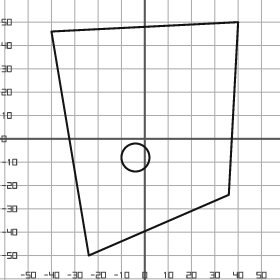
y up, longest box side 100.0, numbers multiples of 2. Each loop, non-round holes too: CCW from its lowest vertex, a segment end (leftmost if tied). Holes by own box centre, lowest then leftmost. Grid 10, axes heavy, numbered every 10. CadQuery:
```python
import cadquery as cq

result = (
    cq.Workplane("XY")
    .moveTo(-24.0, -50.0)
    .lineTo(36.0, -24.0)
    .lineTo(40.0, 50.0)
    .lineTo(-40.0, 46.0)
    .close()
    .moveTo(-4.0, -8.0)
    .circle(6.0)
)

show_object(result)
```